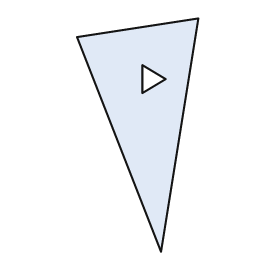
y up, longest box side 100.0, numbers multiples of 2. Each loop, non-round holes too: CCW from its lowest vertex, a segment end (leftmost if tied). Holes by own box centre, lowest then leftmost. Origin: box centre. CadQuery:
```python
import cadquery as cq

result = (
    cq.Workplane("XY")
    .moveTo(10.0, -50.0)
    .lineTo(26.0, 50.0)
    .lineTo(-26.0, 42.0)
    .close()
    .moveTo(2.0, 18.0)
    .lineTo(12.0, 24.0)
    .lineTo(2.0, 30.0)
    .close()
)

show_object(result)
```